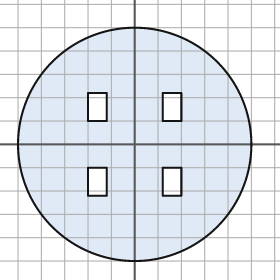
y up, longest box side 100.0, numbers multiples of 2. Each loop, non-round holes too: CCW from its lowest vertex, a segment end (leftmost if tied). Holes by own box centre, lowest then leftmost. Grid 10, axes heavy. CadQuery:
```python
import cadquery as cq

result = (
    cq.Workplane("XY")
    .moveTo(0.0, 0.0)
    .circle(50.0)
    .moveTo(-20.0, -22.0)
    .lineTo(-12.0, -22.0)
    .lineTo(-12.0, -10.0)
    .lineTo(-20.0, -10.0)
    .close()
    .moveTo(12.0, -22.0)
    .lineTo(20.0, -22.0)
    .lineTo(20.0, -10.0)
    .lineTo(12.0, -10.0)
    .close()
    .moveTo(-20.0, 10.0)
    .lineTo(-12.0, 10.0)
    .lineTo(-12.0, 22.0)
    .lineTo(-20.0, 22.0)
    .close()
    .moveTo(12.0, 10.0)
    .lineTo(20.0, 10.0)
    .lineTo(20.0, 22.0)
    .lineTo(12.0, 22.0)
    .close()
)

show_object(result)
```